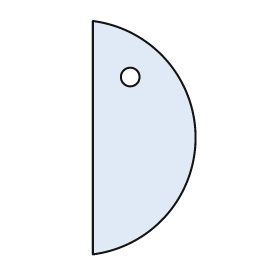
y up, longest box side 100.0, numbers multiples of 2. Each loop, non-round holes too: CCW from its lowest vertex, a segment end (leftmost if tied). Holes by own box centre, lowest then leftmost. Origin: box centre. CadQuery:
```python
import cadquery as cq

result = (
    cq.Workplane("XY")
    .moveTo(-22.0, -50.0)
    .threePointArc((22.0, 0.0), (-22.0, 50.0))
    .close()
    .moveTo(-6.0, 26.0)
    .circle(4.0)
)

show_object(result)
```